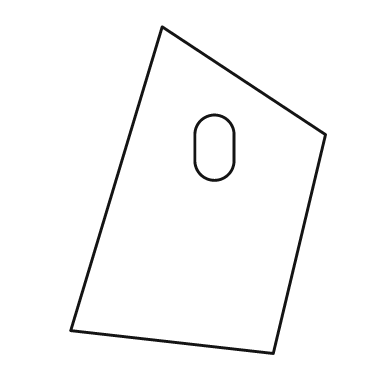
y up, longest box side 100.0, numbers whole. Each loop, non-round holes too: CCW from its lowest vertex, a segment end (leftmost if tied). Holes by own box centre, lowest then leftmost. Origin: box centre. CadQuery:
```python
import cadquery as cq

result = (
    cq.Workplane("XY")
    .moveTo(23.0, -50.0)
    .lineTo(39.0, 17.0)
    .lineTo(-11.0, 50.0)
    .lineTo(-39.0, -43.0)
    .close()
    .moveTo(-1.0, 9.0)
    .threePointArc((5.0, 3.0), (11.0, 9.0))
    .lineTo(11.0, 17.0)
    .threePointArc((5.0, 23.0), (-1.0, 17.0))
    .close()
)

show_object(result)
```